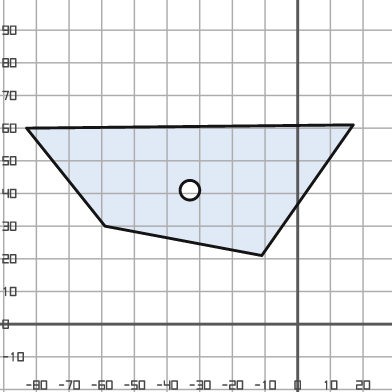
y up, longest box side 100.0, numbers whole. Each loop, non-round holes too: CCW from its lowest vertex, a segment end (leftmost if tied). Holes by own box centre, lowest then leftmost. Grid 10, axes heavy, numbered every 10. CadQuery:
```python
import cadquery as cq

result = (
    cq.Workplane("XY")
    .moveTo(-11.0, 21.0)
    .lineTo(17.0, 61.0)
    .lineTo(-83.0, 60.0)
    .lineTo(-59.0, 30.0)
    .close()
    .moveTo(-33.0, 41.0)
    .circle(3.0)
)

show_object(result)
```